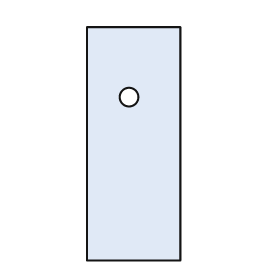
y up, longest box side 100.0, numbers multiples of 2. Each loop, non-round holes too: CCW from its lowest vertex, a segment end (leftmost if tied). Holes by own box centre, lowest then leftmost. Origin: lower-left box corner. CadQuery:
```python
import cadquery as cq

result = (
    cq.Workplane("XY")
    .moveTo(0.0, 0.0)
    .lineTo(40.0, 0.0)
    .lineTo(40.0, 100.0)
    .lineTo(0.0, 100.0)
    .close()
    .moveTo(18.0, 70.0)
    .circle(4.0)
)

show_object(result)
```